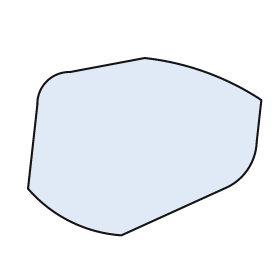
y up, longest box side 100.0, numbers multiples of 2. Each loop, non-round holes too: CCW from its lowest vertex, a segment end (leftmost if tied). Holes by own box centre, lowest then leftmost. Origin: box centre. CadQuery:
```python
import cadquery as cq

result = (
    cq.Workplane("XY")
    .moveTo(-10.0, -38.0)
    .lineTo(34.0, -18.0)
    .threePointArc((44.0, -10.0), (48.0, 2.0))
    .lineTo(50.0, 20.0)
    .threePointArc((26.0, 32.0), (0.0, 38.0))
    .lineTo(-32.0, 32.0)
    .threePointArc((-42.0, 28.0), (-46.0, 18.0))
    .lineTo(-50.0, -18.0)
    .threePointArc((-32.0, -32.0), (-10.0, -38.0))
    .close()
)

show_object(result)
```